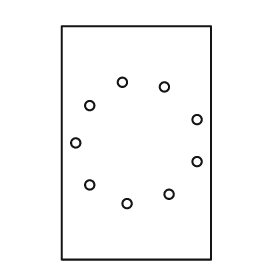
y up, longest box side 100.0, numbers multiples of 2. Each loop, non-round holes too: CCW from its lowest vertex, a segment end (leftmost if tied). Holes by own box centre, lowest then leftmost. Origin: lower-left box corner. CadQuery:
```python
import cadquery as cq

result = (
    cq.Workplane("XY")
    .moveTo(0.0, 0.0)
    .lineTo(64.0, 0.0)
    .lineTo(64.0, 100.0)
    .lineTo(0.0, 100.0)
    .close()
    .moveTo(28.0, 24.0)
    .circle(2.0)
    .moveTo(46.0, 28.0)
    .circle(2.0)
    .moveTo(12.0, 32.0)
    .circle(2.0)
    .moveTo(58.0, 42.0)
    .circle(2.0)
    .moveTo(6.0, 50.0)
    .circle(2.0)
    .moveTo(58.0, 60.0)
    .circle(2.0)
    .moveTo(12.0, 66.0)
    .circle(2.0)
    .moveTo(44.0, 74.0)
    .circle(2.0)
    .moveTo(26.0, 76.0)
    .circle(2.0)
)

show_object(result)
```